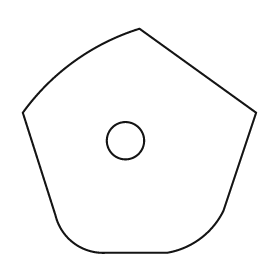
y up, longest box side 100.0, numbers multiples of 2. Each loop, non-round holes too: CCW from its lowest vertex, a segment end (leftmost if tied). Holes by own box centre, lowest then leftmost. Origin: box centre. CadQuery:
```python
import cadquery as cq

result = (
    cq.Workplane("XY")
    .moveTo(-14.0, -48.0)
    .lineTo(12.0, -48.0)
    .threePointArc((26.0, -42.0), (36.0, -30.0))
    .lineTo(50.0, 12.0)
    .lineTo(0.0, 48.0)
    .threePointArc((-28.0, 34.0), (-50.0, 12.0))
    .lineTo(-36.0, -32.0)
    .threePointArc((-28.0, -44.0), (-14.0, -48.0))
    .close()
    .moveTo(-6.0, 0.0)
    .circle(8.0)
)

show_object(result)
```